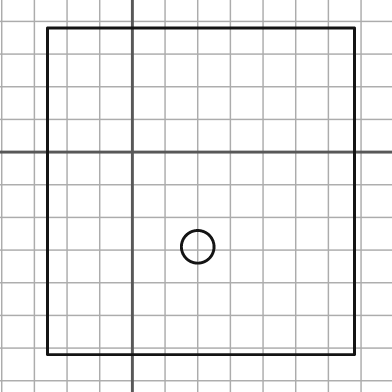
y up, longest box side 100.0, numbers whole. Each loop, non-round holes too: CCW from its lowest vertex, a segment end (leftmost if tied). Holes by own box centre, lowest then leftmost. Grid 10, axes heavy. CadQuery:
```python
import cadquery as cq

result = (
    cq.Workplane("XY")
    .moveTo(-26.0, -62.0)
    .lineTo(68.0, -62.0)
    .lineTo(68.0, 38.0)
    .lineTo(-26.0, 38.0)
    .close()
    .moveTo(20.0, -29.0)
    .circle(5.0)
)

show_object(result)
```